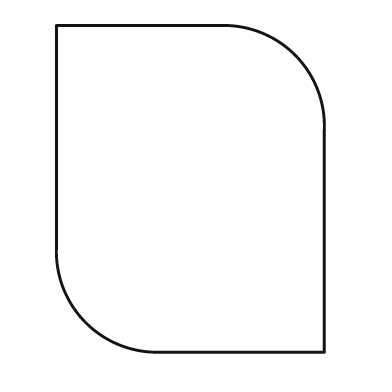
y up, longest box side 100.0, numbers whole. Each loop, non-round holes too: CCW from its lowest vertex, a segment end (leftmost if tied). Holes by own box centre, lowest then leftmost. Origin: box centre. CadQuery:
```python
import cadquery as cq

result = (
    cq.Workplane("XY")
    .moveTo(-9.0, -50.0)
    .lineTo(41.0, -50.0)
    .lineTo(41.0, 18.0)
    .threePointArc((32.0, 41.0), (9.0, 50.0))
    .lineTo(-41.0, 50.0)
    .lineTo(-41.0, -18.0)
    .threePointArc((-32.0, -41.0), (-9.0, -50.0))
    .close()
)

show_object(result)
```